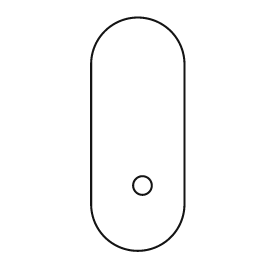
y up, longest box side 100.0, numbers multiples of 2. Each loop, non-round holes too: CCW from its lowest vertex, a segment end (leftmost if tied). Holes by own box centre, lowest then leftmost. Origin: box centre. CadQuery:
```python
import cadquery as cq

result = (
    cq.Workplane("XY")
    .moveTo(-20.0, -30.0)
    .threePointArc((0.0, -50.0), (20.0, -30.0))
    .lineTo(20.0, 30.0)
    .threePointArc((0.0, 50.0), (-20.0, 30.0))
    .close()
    .moveTo(2.0, -22.0)
    .circle(4.0)
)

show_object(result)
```